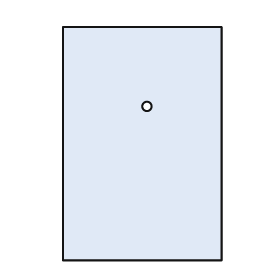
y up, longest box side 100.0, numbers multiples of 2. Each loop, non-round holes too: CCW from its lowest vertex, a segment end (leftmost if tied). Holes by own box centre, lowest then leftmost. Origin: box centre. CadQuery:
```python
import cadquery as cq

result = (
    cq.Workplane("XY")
    .moveTo(-34.0, -50.0)
    .lineTo(34.0, -50.0)
    .lineTo(34.0, 50.0)
    .lineTo(-34.0, 50.0)
    .close()
    .moveTo(2.0, 16.0)
    .circle(2.0)
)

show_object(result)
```